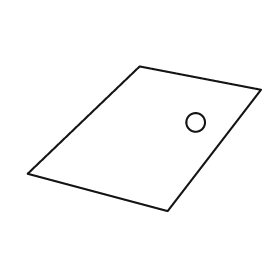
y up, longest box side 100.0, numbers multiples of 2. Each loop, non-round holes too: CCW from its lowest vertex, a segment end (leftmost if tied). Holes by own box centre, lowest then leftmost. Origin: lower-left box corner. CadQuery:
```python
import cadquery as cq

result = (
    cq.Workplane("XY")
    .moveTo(60.0, 0.0)
    .lineTo(100.0, 52.0)
    .lineTo(48.0, 62.0)
    .lineTo(0.0, 16.0)
    .close()
    .moveTo(72.0, 38.0)
    .circle(4.0)
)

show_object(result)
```